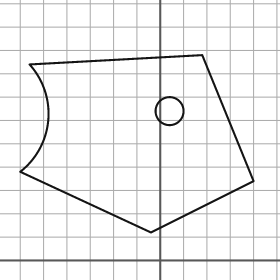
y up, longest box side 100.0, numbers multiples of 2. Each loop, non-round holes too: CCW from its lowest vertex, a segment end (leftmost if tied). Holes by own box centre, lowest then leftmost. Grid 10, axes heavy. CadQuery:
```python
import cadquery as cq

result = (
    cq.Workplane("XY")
    .moveTo(-4.0, 12.0)
    .lineTo(40.0, 34.0)
    .lineTo(18.0, 88.0)
    .lineTo(-56.0, 84.0)
    .threePointArc((-48.0, 60.0), (-60.0, 38.0))
    .close()
    .moveTo(4.0, 64.0)
    .circle(6.0)
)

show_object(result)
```